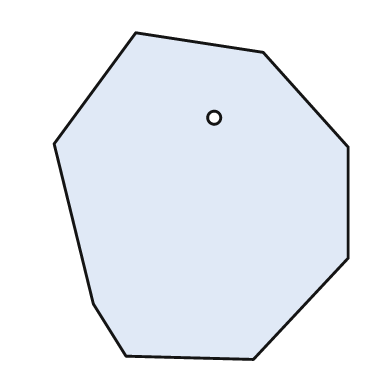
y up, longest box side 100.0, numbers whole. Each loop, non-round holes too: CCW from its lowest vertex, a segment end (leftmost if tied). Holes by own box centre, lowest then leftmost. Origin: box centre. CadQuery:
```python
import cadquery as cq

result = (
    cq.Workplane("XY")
    .moveTo(16.0, -50.0)
    .lineTo(45.0, -19.0)
    .lineTo(45.0, 15.0)
    .lineTo(19.0, 44.0)
    .lineTo(-20.0, 50.0)
    .lineTo(-45.0, 16.0)
    .lineTo(-33.0, -33.0)
    .lineTo(-23.0, -49.0)
    .close()
    .moveTo(4.0, 24.0)
    .circle(2.0)
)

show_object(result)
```